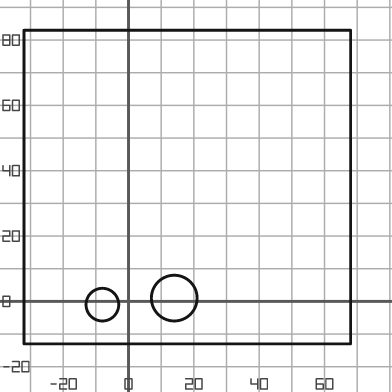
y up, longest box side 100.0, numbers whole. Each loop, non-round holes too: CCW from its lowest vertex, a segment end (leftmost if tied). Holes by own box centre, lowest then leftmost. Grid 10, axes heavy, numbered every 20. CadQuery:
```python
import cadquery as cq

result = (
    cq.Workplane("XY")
    .moveTo(-32.0, -13.0)
    .lineTo(68.0, -13.0)
    .lineTo(68.0, 83.0)
    .lineTo(-32.0, 83.0)
    .close()
    .moveTo(-8.0, -1.0)
    .circle(5.0)
    .moveTo(14.0, 1.0)
    .circle(7.0)
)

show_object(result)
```